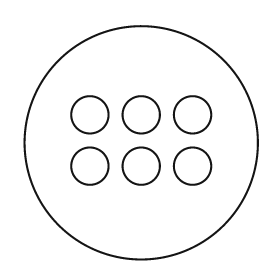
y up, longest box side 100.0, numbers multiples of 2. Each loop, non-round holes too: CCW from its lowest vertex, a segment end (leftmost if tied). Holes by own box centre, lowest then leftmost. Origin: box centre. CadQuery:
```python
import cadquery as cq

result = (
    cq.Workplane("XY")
    .moveTo(0.0, 0.0)
    .circle(50.0)
    .moveTo(-22.0, -10.0)
    .circle(8.0)
    .moveTo(0.0, -10.0)
    .circle(8.0)
    .moveTo(22.0, -10.0)
    .circle(8.0)
    .moveTo(-22.0, 12.0)
    .circle(8.0)
    .moveTo(0.0, 12.0)
    .circle(8.0)
    .moveTo(22.0, 12.0)
    .circle(8.0)
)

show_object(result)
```